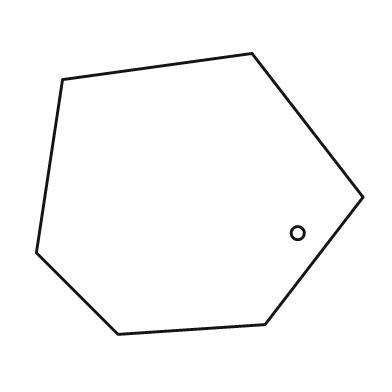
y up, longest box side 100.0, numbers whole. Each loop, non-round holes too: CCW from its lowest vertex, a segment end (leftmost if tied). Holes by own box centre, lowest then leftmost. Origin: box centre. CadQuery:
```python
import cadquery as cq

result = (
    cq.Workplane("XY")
    .moveTo(-25.0, -43.0)
    .lineTo(20.0, -40.0)
    .lineTo(50.0, -1.0)
    .lineTo(16.0, 43.0)
    .lineTo(-42.0, 35.0)
    .lineTo(-50.0, -18.0)
    .close()
    .moveTo(30.0, -12.0)
    .circle(2.0)
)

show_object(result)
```